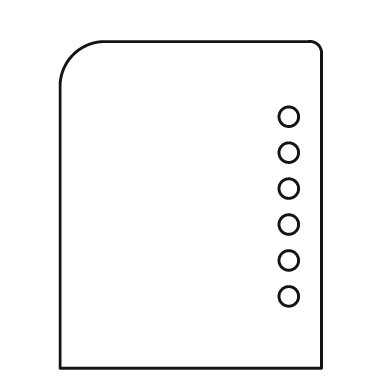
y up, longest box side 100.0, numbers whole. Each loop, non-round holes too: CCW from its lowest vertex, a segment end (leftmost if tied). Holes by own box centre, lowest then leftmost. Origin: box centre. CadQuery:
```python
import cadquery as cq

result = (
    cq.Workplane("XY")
    .moveTo(-40.0, -50.0)
    .lineTo(40.0, -50.0)
    .lineTo(40.0, 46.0)
    .threePointArc((39.0, 49.0), (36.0, 50.0))
    .lineTo(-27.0, 50.0)
    .threePointArc((-36.0, 46.0), (-40.0, 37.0))
    .close()
    .moveTo(30.0, -28.0)
    .circle(3.0)
    .moveTo(30.0, -17.0)
    .circle(3.0)
    .moveTo(30.0, -6.0)
    .circle(3.0)
    .moveTo(30.0, 5.0)
    .circle(3.0)
    .moveTo(30.0, 16.0)
    .circle(3.0)
    .moveTo(30.0, 27.0)
    .circle(3.0)
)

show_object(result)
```